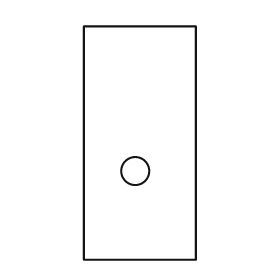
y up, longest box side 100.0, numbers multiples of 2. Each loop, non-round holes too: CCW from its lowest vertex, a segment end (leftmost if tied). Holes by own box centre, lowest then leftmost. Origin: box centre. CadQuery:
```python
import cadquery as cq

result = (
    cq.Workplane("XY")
    .moveTo(-24.0, -50.0)
    .lineTo(24.0, -50.0)
    .lineTo(24.0, 50.0)
    .lineTo(-24.0, 50.0)
    .close()
    .moveTo(-2.0, -12.0)
    .circle(6.0)
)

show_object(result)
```